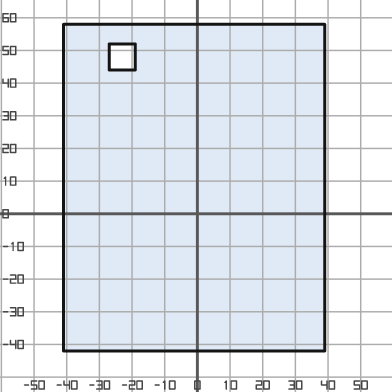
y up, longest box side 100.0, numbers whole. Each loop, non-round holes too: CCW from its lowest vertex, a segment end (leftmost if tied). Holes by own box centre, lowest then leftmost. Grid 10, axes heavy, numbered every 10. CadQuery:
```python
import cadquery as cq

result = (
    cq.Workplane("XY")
    .moveTo(-41.0, -42.0)
    .lineTo(39.0, -42.0)
    .lineTo(39.0, 58.0)
    .lineTo(-41.0, 58.0)
    .close()
    .moveTo(-27.0, 44.0)
    .lineTo(-19.0, 44.0)
    .lineTo(-19.0, 52.0)
    .lineTo(-27.0, 52.0)
    .close()
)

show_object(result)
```